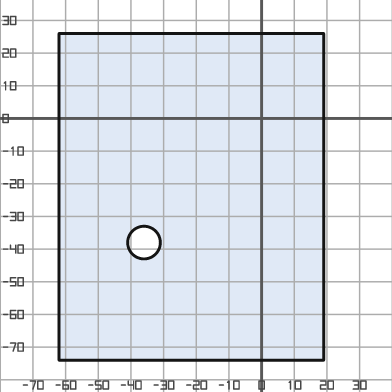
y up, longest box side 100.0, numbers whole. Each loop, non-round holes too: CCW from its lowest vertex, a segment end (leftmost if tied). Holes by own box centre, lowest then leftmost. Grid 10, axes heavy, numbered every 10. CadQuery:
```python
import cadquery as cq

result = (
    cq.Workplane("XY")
    .moveTo(-62.0, -74.0)
    .lineTo(19.0, -74.0)
    .lineTo(19.0, 26.0)
    .lineTo(-62.0, 26.0)
    .close()
    .moveTo(-36.0, -38.0)
    .circle(5.0)
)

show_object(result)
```